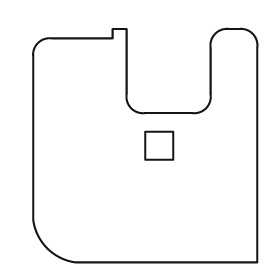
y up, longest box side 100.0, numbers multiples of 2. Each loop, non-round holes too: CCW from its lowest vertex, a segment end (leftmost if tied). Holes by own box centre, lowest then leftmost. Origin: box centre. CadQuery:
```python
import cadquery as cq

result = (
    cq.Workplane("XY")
    .moveTo(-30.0, -50.0)
    .lineTo(48.0, -50.0)
    .lineTo(48.0, 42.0)
    .threePointArc((46.0, 48.0), (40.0, 50.0))
    .lineTo(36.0, 50.0)
    .threePointArc((30.0, 48.0), (28.0, 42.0))
    .lineTo(28.0, 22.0)
    .threePointArc((26.0, 16.0), (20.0, 14.0))
    .lineTo(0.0, 14.0)
    .threePointArc((-6.0, 16.0), (-8.0, 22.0))
    .lineTo(-8.0, 50.0)
    .lineTo(-14.0, 50.0)
    .lineTo(-14.0, 46.0)
    .lineTo(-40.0, 46.0)
    .threePointArc((-46.0, 44.0), (-48.0, 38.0))
    .lineTo(-48.0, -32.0)
    .threePointArc((-42.0, -44.0), (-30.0, -50.0))
    .close()
    .moveTo(0.0, -6.0)
    .lineTo(12.0, -6.0)
    .lineTo(12.0, 6.0)
    .lineTo(0.0, 6.0)
    .close()
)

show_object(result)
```